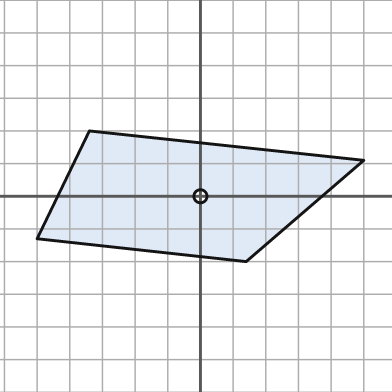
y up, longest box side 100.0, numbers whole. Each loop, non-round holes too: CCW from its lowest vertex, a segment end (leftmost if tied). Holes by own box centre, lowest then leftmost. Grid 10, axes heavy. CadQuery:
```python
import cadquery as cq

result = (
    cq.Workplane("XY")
    .moveTo(14.0, -20.0)
    .lineTo(50.0, 11.0)
    .lineTo(-34.0, 20.0)
    .lineTo(-50.0, -13.0)
    .close()
    .moveTo(0.0, 0.0)
    .circle(2.0)
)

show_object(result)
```